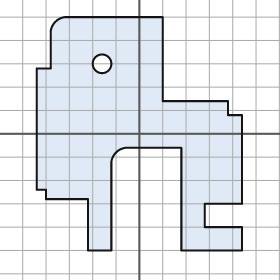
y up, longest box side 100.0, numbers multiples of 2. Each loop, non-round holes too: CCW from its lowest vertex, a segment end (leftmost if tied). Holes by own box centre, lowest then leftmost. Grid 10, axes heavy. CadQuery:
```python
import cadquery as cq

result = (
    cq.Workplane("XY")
    .moveTo(-22.0, -50.0)
    .lineTo(-12.0, -50.0)
    .lineTo(-12.0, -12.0)
    .threePointArc((-10.0, -8.0), (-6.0, -6.0))
    .lineTo(18.0, -6.0)
    .lineTo(18.0, -50.0)
    .lineTo(44.0, -50.0)
    .lineTo(44.0, -40.0)
    .lineTo(28.0, -40.0)
    .lineTo(28.0, -30.0)
    .lineTo(44.0, -30.0)
    .lineTo(44.0, 8.0)
    .lineTo(38.0, 8.0)
    .lineTo(38.0, 14.0)
    .lineTo(10.0, 14.0)
    .lineTo(10.0, 50.0)
    .lineTo(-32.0, 50.0)
    .threePointArc((-36.0, 48.0), (-38.0, 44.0))
    .lineTo(-38.0, 28.0)
    .lineTo(-44.0, 28.0)
    .lineTo(-44.0, -24.0)
    .lineTo(-40.0, -24.0)
    .lineTo(-40.0, -28.0)
    .lineTo(-22.0, -28.0)
    .close()
    .moveTo(-16.0, 30.0)
    .circle(4.0)
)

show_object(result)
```